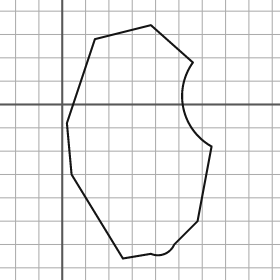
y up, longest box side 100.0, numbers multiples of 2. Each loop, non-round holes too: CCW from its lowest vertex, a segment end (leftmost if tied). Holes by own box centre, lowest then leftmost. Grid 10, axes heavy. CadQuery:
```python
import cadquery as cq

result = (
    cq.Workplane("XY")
    .moveTo(26.0, -66.0)
    .lineTo(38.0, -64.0)
    .threePointArc((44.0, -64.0), (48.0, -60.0))
    .lineTo(58.0, -50.0)
    .lineTo(64.0, -18.0)
    .threePointArc((52.0, -2.0), (56.0, 18.0))
    .lineTo(38.0, 34.0)
    .lineTo(14.0, 28.0)
    .lineTo(2.0, -8.0)
    .lineTo(4.0, -30.0)
    .close()
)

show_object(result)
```